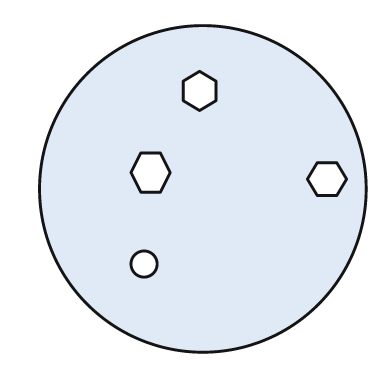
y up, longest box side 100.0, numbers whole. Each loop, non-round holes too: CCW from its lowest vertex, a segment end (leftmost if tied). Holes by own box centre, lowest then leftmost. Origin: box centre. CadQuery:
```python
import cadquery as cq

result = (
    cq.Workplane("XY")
    .moveTo(0.0, 0.0)
    .circle(50.0)
    .moveTo(-18.0, -23.0)
    .circle(4.0)
    .moveTo(35.0, -2.0)
    .lineTo(41.0, -2.0)
    .lineTo(44.0, 3.0)
    .lineTo(41.0, 8.0)
    .lineTo(35.0, 8.0)
    .lineTo(32.0, 3.0)
    .close()
    .moveTo(-19.0, -1.0)
    .lineTo(-13.0, -1.0)
    .lineTo(-10.0, 5.0)
    .lineTo(-13.0, 11.0)
    .lineTo(-19.0, 11.0)
    .lineTo(-22.0, 5.0)
    .close()
    .moveTo(-1.0, 24.0)
    .lineTo(4.0, 27.0)
    .lineTo(4.0, 33.0)
    .lineTo(-1.0, 36.0)
    .lineTo(-6.0, 33.0)
    .lineTo(-6.0, 27.0)
    .close()
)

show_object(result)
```